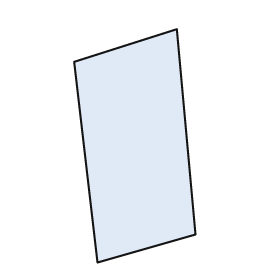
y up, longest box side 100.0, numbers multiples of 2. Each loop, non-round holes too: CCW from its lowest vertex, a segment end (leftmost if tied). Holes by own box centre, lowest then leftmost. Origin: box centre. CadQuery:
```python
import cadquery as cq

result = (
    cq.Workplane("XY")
    .moveTo(-16.0, -50.0)
    .lineTo(26.0, -38.0)
    .lineTo(18.0, 50.0)
    .lineTo(-26.0, 36.0)
    .close()
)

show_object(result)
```